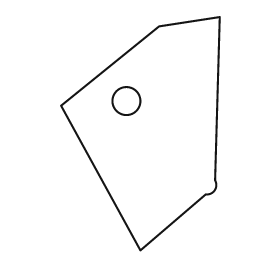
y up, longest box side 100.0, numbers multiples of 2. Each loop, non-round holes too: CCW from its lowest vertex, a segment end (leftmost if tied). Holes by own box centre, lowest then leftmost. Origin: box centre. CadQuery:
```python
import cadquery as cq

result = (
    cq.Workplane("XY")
    .moveTo(0.0, -50.0)
    .lineTo(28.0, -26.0)
    .threePointArc((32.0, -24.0), (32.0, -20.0))
    .lineTo(34.0, 50.0)
    .lineTo(8.0, 46.0)
    .lineTo(-34.0, 12.0)
    .close()
    .moveTo(-6.0, 14.0)
    .circle(6.0)
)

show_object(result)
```